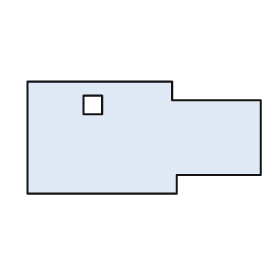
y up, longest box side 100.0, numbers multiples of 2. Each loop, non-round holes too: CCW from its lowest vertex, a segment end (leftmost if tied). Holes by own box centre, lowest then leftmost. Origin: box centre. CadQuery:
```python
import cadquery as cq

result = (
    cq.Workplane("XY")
    .moveTo(-50.0, -24.0)
    .lineTo(14.0, -24.0)
    .lineTo(14.0, -16.0)
    .lineTo(50.0, -16.0)
    .lineTo(50.0, 16.0)
    .lineTo(12.0, 16.0)
    .lineTo(12.0, 24.0)
    .lineTo(-50.0, 24.0)
    .close()
    .moveTo(-26.0, 10.0)
    .lineTo(-18.0, 10.0)
    .lineTo(-18.0, 18.0)
    .lineTo(-26.0, 18.0)
    .close()
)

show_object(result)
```